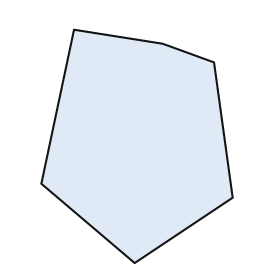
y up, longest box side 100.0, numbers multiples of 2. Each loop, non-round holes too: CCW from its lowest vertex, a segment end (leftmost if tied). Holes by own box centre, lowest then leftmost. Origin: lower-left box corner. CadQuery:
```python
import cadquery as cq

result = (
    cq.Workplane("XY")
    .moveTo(40.0, 0.0)
    .lineTo(82.0, 28.0)
    .lineTo(74.0, 86.0)
    .lineTo(52.0, 94.0)
    .lineTo(14.0, 100.0)
    .lineTo(0.0, 34.0)
    .close()
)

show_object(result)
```